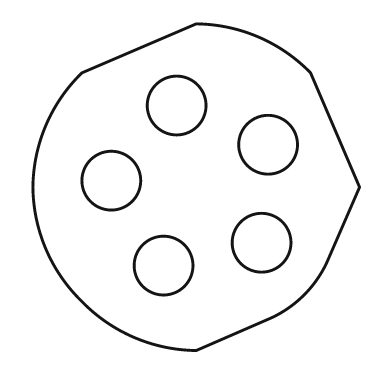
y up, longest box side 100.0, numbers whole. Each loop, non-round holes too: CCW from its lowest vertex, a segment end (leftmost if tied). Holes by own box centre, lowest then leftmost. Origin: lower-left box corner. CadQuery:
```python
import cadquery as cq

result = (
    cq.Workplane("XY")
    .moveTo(50.0, 0.0)
    .lineTo(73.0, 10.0)
    .threePointArc((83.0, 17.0), (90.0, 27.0))
    .lineTo(100.0, 50.0)
    .lineTo(85.0, 85.0)
    .threePointArc((69.0, 96.0), (50.0, 100.0))
    .lineTo(15.0, 85.0)
    .threePointArc((4.0, 69.0), (0.0, 50.0))
    .threePointArc((4.0, 31.0), (15.0, 15.0))
    .threePointArc((31.0, 4.0), (50.0, 0.0))
    .close()
    .moveTo(40.0, 26.0)
    .circle(9.0)
    .moveTo(70.0, 33.0)
    .circle(9.0)
    .moveTo(24.0, 52.0)
    .circle(9.0)
    .moveTo(72.0, 63.0)
    .circle(9.0)
    .moveTo(44.0, 75.0)
    .circle(9.0)
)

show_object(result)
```